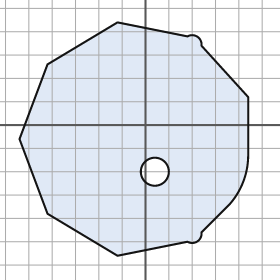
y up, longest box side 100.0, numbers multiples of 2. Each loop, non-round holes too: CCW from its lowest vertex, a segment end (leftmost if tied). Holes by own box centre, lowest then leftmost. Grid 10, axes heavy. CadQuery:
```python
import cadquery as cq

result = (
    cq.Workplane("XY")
    .moveTo(-12.0, -56.0)
    .lineTo(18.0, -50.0)
    .threePointArc((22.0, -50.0), (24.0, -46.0))
    .lineTo(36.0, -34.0)
    .threePointArc((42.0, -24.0), (44.0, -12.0))
    .lineTo(44.0, 12.0)
    .lineTo(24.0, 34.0)
    .threePointArc((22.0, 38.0), (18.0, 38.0))
    .lineTo(-12.0, 44.0)
    .lineTo(-42.0, 26.0)
    .lineTo(-54.0, -6.0)
    .lineTo(-42.0, -38.0)
    .close()
    .moveTo(4.0, -20.0)
    .circle(6.0)
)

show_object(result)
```